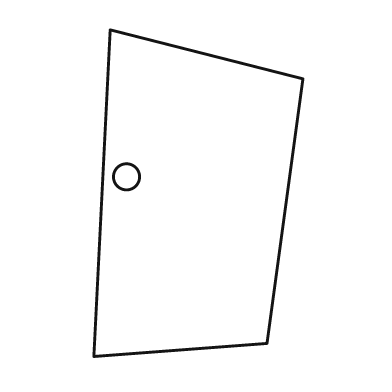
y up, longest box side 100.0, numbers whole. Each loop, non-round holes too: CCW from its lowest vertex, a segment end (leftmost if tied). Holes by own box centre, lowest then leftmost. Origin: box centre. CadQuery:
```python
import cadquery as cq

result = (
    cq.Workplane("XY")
    .moveTo(-32.0, -50.0)
    .lineTo(21.0, -46.0)
    .lineTo(32.0, 35.0)
    .lineTo(-27.0, 50.0)
    .close()
    .moveTo(-22.0, 5.0)
    .circle(4.0)
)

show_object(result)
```